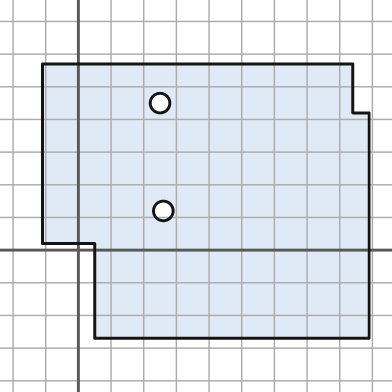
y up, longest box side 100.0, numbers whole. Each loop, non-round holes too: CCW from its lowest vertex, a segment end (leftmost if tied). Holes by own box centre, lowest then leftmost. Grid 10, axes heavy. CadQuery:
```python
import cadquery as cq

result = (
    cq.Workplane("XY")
    .moveTo(5.0, -27.0)
    .lineTo(89.0, -27.0)
    .lineTo(89.0, 42.0)
    .lineTo(84.0, 42.0)
    .lineTo(84.0, 57.0)
    .lineTo(-11.0, 57.0)
    .lineTo(-11.0, 2.0)
    .lineTo(5.0, 2.0)
    .close()
    .moveTo(26.0, 12.0)
    .circle(3.0)
    .moveTo(25.0, 45.0)
    .circle(3.0)
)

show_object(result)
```